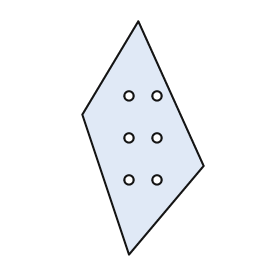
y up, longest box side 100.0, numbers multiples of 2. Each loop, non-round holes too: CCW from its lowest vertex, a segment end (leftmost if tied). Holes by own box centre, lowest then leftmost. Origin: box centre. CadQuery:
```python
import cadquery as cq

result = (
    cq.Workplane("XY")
    .moveTo(-6.0, -50.0)
    .lineTo(26.0, -12.0)
    .lineTo(-2.0, 50.0)
    .lineTo(-26.0, 10.0)
    .close()
    .moveTo(-6.0, -18.0)
    .circle(2.0)
    .moveTo(6.0, -18.0)
    .circle(2.0)
    .moveTo(-6.0, 0.0)
    .circle(2.0)
    .moveTo(6.0, 0.0)
    .circle(2.0)
    .moveTo(-6.0, 18.0)
    .circle(2.0)
    .moveTo(6.0, 18.0)
    .circle(2.0)
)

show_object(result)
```